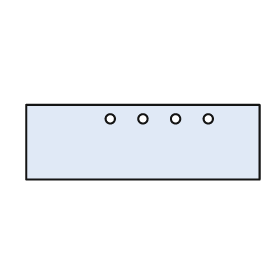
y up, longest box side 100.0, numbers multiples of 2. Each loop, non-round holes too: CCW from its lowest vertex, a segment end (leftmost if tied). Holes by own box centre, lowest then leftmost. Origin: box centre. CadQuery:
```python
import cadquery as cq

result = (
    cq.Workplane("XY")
    .moveTo(-50.0, -16.0)
    .lineTo(50.0, -16.0)
    .lineTo(50.0, 16.0)
    .lineTo(-50.0, 16.0)
    .close()
    .moveTo(-14.0, 10.0)
    .circle(2.0)
    .moveTo(0.0, 10.0)
    .circle(2.0)
    .moveTo(14.0, 10.0)
    .circle(2.0)
    .moveTo(28.0, 10.0)
    .circle(2.0)
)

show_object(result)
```